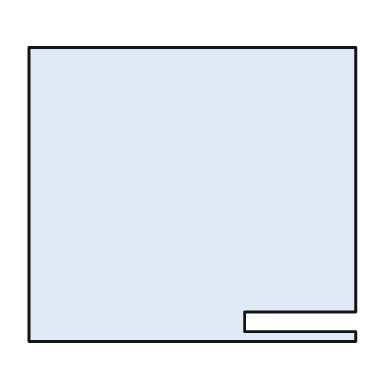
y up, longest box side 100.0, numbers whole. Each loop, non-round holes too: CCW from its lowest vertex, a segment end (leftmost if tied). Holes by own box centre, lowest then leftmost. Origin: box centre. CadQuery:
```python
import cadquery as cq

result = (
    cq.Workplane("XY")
    .moveTo(-50.0, -45.0)
    .lineTo(50.0, -45.0)
    .lineTo(50.0, -42.0)
    .lineTo(16.0, -42.0)
    .lineTo(16.0, -36.0)
    .lineTo(50.0, -36.0)
    .lineTo(50.0, 45.0)
    .lineTo(-50.0, 45.0)
    .close()
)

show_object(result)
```